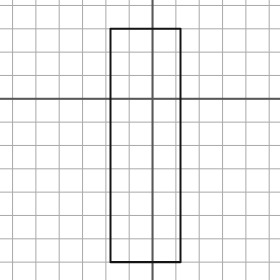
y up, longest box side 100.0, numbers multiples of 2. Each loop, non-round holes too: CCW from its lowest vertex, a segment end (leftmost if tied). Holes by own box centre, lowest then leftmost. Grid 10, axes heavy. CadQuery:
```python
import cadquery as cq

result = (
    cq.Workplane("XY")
    .moveTo(-18.0, -70.0)
    .lineTo(12.0, -70.0)
    .lineTo(12.0, 30.0)
    .lineTo(-18.0, 30.0)
    .close()
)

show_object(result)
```